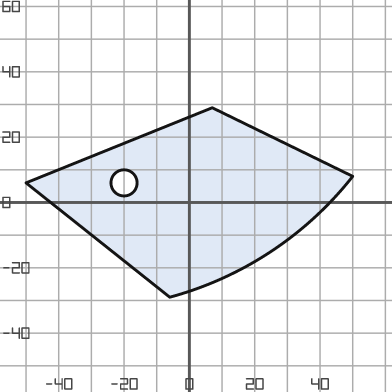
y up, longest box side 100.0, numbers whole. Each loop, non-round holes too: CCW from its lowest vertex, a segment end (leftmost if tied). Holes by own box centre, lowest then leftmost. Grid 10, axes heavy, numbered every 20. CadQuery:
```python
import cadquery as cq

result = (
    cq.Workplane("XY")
    .moveTo(-6.0, -29.0)
    .threePointArc((25.0, -15.0), (50.0, 8.0))
    .lineTo(7.0, 29.0)
    .lineTo(-50.0, 6.0)
    .close()
    .moveTo(-20.0, 6.0)
    .circle(4.0)
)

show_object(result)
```